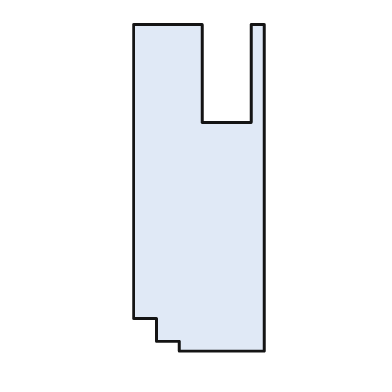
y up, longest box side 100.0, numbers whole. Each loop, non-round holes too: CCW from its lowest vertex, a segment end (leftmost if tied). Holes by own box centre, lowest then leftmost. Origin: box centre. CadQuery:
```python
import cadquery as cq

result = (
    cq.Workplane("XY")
    .moveTo(-6.0, -50.0)
    .lineTo(20.0, -50.0)
    .lineTo(20.0, 50.0)
    .lineTo(16.0, 50.0)
    .lineTo(16.0, 20.0)
    .lineTo(1.0, 20.0)
    .lineTo(1.0, 50.0)
    .lineTo(-20.0, 50.0)
    .lineTo(-20.0, -40.0)
    .lineTo(-13.0, -40.0)
    .lineTo(-13.0, -47.0)
    .lineTo(-6.0, -47.0)
    .close()
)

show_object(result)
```